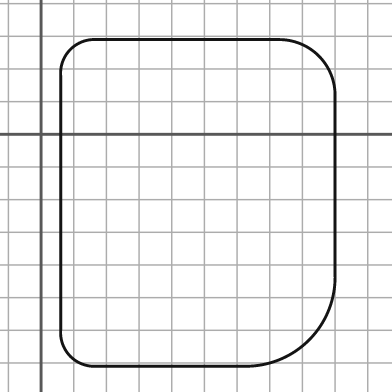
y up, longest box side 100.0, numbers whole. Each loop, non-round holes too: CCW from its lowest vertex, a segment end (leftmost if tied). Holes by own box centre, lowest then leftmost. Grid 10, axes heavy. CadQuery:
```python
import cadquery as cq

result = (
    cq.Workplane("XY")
    .moveTo(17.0, -71.0)
    .lineTo(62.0, -71.0)
    .threePointArc((82.0, -63.0), (90.0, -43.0))
    .lineTo(90.0, 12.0)
    .threePointArc((85.0, 24.0), (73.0, 29.0))
    .lineTo(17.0, 29.0)
    .threePointArc((9.0, 26.0), (6.0, 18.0))
    .lineTo(6.0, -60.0)
    .threePointArc((9.0, -68.0), (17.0, -71.0))
    .close()
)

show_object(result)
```